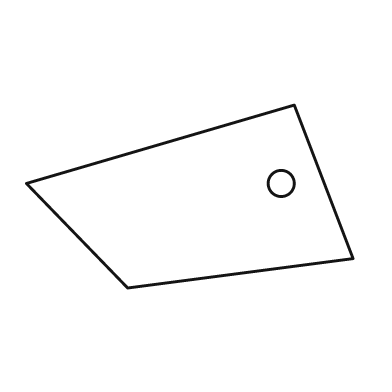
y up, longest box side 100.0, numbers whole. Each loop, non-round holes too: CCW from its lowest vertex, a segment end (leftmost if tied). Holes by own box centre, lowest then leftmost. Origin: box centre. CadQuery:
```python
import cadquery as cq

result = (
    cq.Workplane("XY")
    .moveTo(-19.0, -28.0)
    .lineTo(50.0, -19.0)
    .lineTo(32.0, 28.0)
    .lineTo(-50.0, 4.0)
    .close()
    .moveTo(28.0, 4.0)
    .circle(4.0)
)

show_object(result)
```